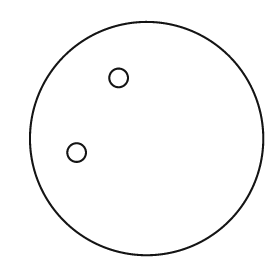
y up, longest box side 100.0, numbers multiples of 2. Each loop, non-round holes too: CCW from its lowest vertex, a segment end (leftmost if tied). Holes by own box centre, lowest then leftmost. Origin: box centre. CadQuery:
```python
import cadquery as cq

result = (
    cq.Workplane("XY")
    .moveTo(0.0, 0.0)
    .circle(50.0)
    .moveTo(-30.0, -6.0)
    .circle(4.0)
    .moveTo(-12.0, 26.0)
    .circle(4.0)
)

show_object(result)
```